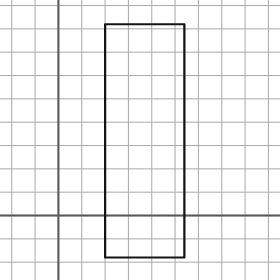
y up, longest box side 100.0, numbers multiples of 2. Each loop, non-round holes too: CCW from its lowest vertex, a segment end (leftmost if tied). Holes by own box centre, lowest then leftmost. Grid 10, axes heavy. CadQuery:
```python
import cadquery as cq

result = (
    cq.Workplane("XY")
    .moveTo(20.0, -18.0)
    .lineTo(54.0, -18.0)
    .lineTo(54.0, 82.0)
    .lineTo(20.0, 82.0)
    .close()
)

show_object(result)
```